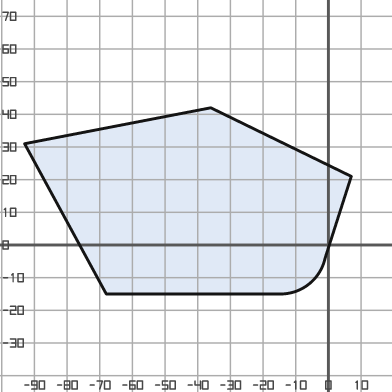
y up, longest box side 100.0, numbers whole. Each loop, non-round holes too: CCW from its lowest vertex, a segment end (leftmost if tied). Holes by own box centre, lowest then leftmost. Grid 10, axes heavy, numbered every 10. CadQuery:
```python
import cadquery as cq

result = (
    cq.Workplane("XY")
    .moveTo(-68.0, -15.0)
    .lineTo(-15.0, -15.0)
    .threePointArc((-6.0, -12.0), (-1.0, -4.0))
    .lineTo(7.0, 21.0)
    .lineTo(-36.0, 42.0)
    .lineTo(-93.0, 31.0)
    .close()
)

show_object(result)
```